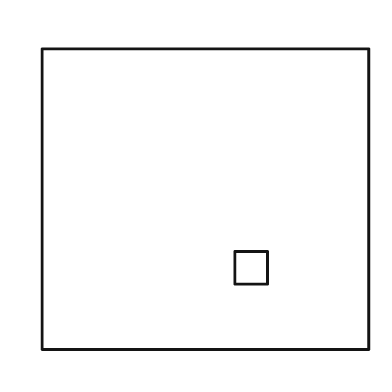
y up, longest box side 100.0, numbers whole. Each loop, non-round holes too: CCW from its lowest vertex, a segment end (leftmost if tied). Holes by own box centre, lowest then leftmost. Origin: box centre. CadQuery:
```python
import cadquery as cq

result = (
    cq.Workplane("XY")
    .moveTo(-50.0, -46.0)
    .lineTo(50.0, -46.0)
    .lineTo(50.0, 46.0)
    .lineTo(-50.0, 46.0)
    .close()
    .moveTo(9.0, -26.0)
    .lineTo(19.0, -26.0)
    .lineTo(19.0, -16.0)
    .lineTo(9.0, -16.0)
    .close()
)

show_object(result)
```